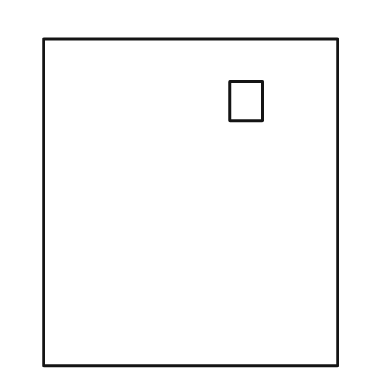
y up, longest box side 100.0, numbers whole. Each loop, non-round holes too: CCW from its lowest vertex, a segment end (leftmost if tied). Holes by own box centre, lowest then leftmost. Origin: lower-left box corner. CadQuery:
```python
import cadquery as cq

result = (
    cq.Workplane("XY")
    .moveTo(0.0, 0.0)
    .lineTo(90.0, 0.0)
    .lineTo(90.0, 100.0)
    .lineTo(0.0, 100.0)
    .close()
    .moveTo(57.0, 75.0)
    .lineTo(67.0, 75.0)
    .lineTo(67.0, 87.0)
    .lineTo(57.0, 87.0)
    .close()
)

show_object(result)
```